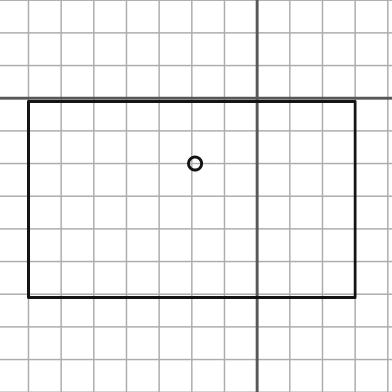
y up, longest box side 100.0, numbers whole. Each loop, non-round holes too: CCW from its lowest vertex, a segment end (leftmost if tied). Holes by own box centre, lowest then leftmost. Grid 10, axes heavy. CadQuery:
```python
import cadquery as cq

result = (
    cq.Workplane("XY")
    .moveTo(-70.0, -61.0)
    .lineTo(30.0, -61.0)
    .lineTo(30.0, -1.0)
    .lineTo(-70.0, -1.0)
    .close()
    .moveTo(-19.0, -20.0)
    .circle(2.0)
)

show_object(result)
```